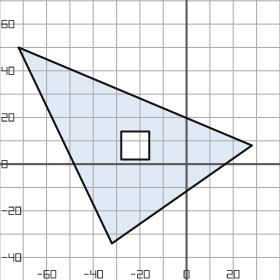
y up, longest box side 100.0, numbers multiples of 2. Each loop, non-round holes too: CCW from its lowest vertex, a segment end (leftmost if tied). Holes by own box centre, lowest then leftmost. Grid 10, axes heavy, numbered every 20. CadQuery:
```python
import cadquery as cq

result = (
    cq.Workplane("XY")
    .moveTo(-32.0, -34.0)
    .lineTo(28.0, 8.0)
    .lineTo(-72.0, 50.0)
    .close()
    .moveTo(-28.0, 2.0)
    .lineTo(-16.0, 2.0)
    .lineTo(-16.0, 14.0)
    .lineTo(-28.0, 14.0)
    .close()
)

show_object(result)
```